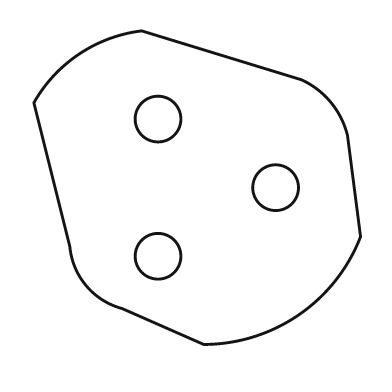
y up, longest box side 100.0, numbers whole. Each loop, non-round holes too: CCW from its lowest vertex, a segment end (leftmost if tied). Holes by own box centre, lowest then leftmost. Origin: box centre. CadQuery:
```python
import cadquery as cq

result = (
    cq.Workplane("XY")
    .moveTo(2.0, -48.0)
    .threePointArc((31.0, -39.0), (50.0, -15.0))
    .lineTo(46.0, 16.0)
    .threePointArc((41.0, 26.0), (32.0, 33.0))
    .lineTo(-17.0, 48.0)
    .threePointArc((-36.0, 41.0), (-50.0, 26.0))
    .lineTo(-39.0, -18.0)
    .threePointArc((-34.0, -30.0), (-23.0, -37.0))
    .close()
    .moveTo(-12.0, -21.0)
    .circle(7.0)
    .moveTo(24.0, 0.0)
    .circle(7.0)
    .moveTo(-12.0, 21.0)
    .circle(7.0)
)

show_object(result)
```